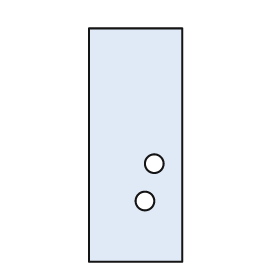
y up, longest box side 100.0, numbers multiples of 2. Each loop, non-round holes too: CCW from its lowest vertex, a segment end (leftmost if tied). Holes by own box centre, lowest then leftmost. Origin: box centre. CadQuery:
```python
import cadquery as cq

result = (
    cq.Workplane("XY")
    .moveTo(-20.0, -50.0)
    .lineTo(20.0, -50.0)
    .lineTo(20.0, 50.0)
    .lineTo(-20.0, 50.0)
    .close()
    .moveTo(4.0, -24.0)
    .circle(4.0)
    .moveTo(8.0, -8.0)
    .circle(4.0)
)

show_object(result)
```